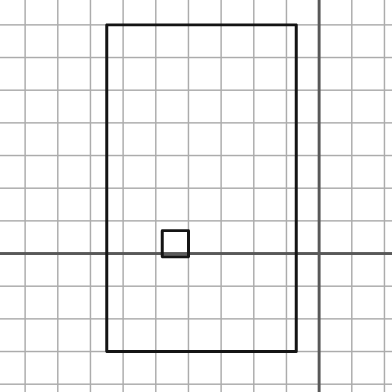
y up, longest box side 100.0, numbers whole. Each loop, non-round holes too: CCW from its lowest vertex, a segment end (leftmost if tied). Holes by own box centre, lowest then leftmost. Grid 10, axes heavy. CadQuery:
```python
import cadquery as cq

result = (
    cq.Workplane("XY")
    .moveTo(-65.0, -30.0)
    .lineTo(-7.0, -30.0)
    .lineTo(-7.0, 70.0)
    .lineTo(-65.0, 70.0)
    .close()
    .moveTo(-48.0, -1.0)
    .lineTo(-40.0, -1.0)
    .lineTo(-40.0, 7.0)
    .lineTo(-48.0, 7.0)
    .close()
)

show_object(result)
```